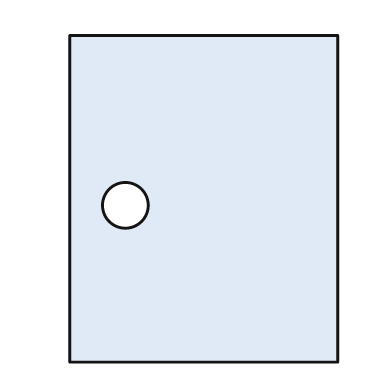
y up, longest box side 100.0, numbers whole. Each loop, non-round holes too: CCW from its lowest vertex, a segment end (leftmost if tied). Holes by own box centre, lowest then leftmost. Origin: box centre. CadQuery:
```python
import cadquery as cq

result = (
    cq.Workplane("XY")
    .moveTo(-41.0, -50.0)
    .lineTo(41.0, -50.0)
    .lineTo(41.0, 50.0)
    .lineTo(-41.0, 50.0)
    .close()
    .moveTo(-24.0, -2.0)
    .circle(7.0)
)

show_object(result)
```